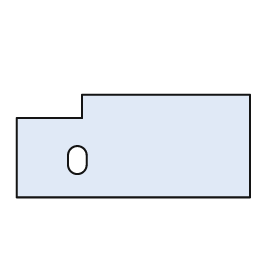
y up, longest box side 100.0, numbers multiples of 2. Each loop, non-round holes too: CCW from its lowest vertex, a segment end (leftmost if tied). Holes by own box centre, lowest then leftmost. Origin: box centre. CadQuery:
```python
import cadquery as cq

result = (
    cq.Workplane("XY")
    .moveTo(-50.0, -22.0)
    .lineTo(50.0, -22.0)
    .lineTo(50.0, 22.0)
    .lineTo(-22.0, 22.0)
    .lineTo(-22.0, 12.0)
    .lineTo(-50.0, 12.0)
    .close()
    .moveTo(-28.0, -8.0)
    .threePointArc((-24.0, -12.0), (-20.0, -8.0))
    .lineTo(-20.0, -4.0)
    .threePointArc((-24.0, 0.0), (-28.0, -4.0))
    .close()
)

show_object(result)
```